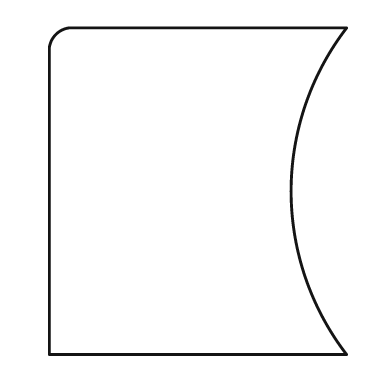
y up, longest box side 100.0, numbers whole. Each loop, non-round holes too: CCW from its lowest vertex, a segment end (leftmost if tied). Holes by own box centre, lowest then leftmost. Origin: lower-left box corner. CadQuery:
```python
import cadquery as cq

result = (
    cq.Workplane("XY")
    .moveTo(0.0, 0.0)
    .lineTo(91.0, 0.0)
    .threePointArc((74.0, 50.0), (91.0, 100.0))
    .lineTo(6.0, 100.0)
    .threePointArc((2.0, 98.0), (0.0, 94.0))
    .close()
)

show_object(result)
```